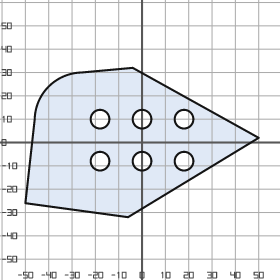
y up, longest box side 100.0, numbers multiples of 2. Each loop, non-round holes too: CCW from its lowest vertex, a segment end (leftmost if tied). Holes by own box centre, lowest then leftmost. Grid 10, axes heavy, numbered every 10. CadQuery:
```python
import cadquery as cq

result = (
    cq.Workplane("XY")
    .moveTo(-6.0, -32.0)
    .lineTo(50.0, 2.0)
    .lineTo(-4.0, 32.0)
    .lineTo(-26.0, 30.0)
    .threePointArc((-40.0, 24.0), (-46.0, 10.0))
    .lineTo(-50.0, -26.0)
    .close()
    .moveTo(-18.0, -8.0)
    .circle(4.0)
    .moveTo(0.0, -8.0)
    .circle(4.0)
    .moveTo(18.0, -8.0)
    .circle(4.0)
    .moveTo(-18.0, 10.0)
    .circle(4.0)
    .moveTo(0.0, 10.0)
    .circle(4.0)
    .moveTo(18.0, 10.0)
    .circle(4.0)
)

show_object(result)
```